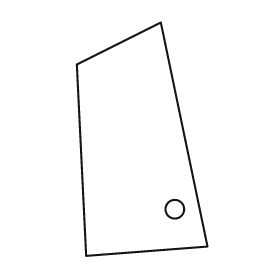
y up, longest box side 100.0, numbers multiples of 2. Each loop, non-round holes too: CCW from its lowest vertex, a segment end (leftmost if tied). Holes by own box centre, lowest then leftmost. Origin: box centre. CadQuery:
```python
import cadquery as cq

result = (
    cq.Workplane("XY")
    .moveTo(-24.0, -50.0)
    .lineTo(28.0, -46.0)
    .lineTo(8.0, 50.0)
    .lineTo(-28.0, 32.0)
    .close()
    .moveTo(14.0, -30.0)
    .circle(4.0)
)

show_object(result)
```